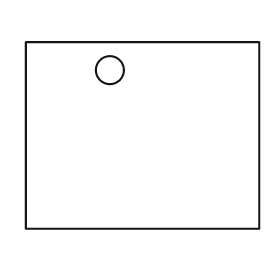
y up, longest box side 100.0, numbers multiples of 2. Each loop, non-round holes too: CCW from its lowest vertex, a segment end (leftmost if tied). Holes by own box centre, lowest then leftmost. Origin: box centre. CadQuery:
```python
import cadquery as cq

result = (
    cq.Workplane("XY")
    .moveTo(-50.0, -40.0)
    .lineTo(50.0, -40.0)
    .lineTo(50.0, 40.0)
    .lineTo(-50.0, 40.0)
    .close()
    .moveTo(-14.0, 28.0)
    .circle(6.0)
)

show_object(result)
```